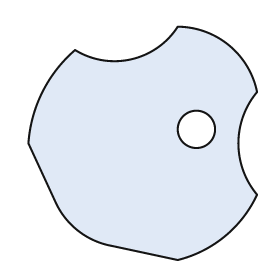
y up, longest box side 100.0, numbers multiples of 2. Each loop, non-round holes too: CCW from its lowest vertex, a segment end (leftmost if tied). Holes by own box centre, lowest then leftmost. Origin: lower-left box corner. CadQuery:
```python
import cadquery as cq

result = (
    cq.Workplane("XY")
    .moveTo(64.0, 0.0)
    .threePointArc((84.0, 10.0), (98.0, 28.0))
    .threePointArc((90.0, 50.0), (98.0, 72.0))
    .threePointArc((86.0, 92.0), (64.0, 100.0))
    .threePointArc((44.0, 86.0), (20.0, 90.0))
    .threePointArc((6.0, 72.0), (0.0, 50.0))
    .lineTo(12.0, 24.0)
    .threePointArc((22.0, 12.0), (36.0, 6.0))
    .close()
    .moveTo(72.0, 56.0)
    .circle(8.0)
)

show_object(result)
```